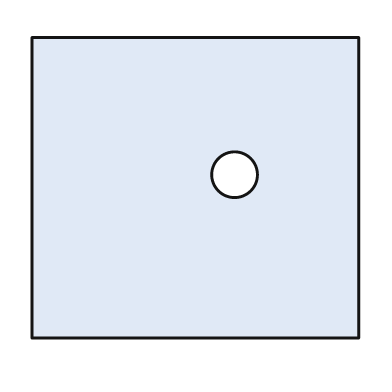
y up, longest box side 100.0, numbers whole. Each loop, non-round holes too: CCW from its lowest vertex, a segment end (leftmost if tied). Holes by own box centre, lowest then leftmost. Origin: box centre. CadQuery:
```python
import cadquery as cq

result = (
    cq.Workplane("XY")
    .moveTo(-50.0, -46.0)
    .lineTo(50.0, -46.0)
    .lineTo(50.0, 46.0)
    .lineTo(-50.0, 46.0)
    .close()
    .moveTo(12.0, 4.0)
    .circle(7.0)
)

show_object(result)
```